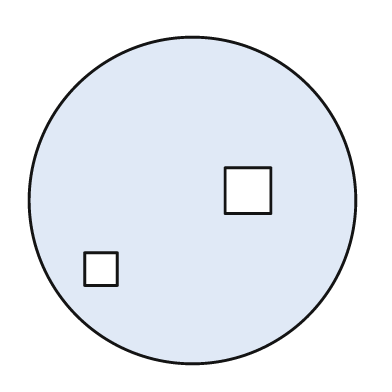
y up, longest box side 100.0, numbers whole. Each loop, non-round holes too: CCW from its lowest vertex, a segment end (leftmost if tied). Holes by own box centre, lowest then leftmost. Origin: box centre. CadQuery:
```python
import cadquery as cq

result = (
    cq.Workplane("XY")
    .moveTo(0.0, 0.0)
    .circle(50.0)
    .moveTo(-33.0, -26.0)
    .lineTo(-23.0, -26.0)
    .lineTo(-23.0, -16.0)
    .lineTo(-33.0, -16.0)
    .close()
    .moveTo(10.0, -4.0)
    .lineTo(24.0, -4.0)
    .lineTo(24.0, 10.0)
    .lineTo(10.0, 10.0)
    .close()
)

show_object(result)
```